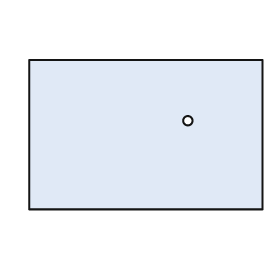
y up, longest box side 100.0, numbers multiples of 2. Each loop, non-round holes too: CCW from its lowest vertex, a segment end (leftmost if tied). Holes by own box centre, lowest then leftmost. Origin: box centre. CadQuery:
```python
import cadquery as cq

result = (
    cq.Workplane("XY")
    .moveTo(-50.0, -32.0)
    .lineTo(50.0, -32.0)
    .lineTo(50.0, 32.0)
    .lineTo(-50.0, 32.0)
    .close()
    .moveTo(18.0, 6.0)
    .circle(2.0)
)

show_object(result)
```